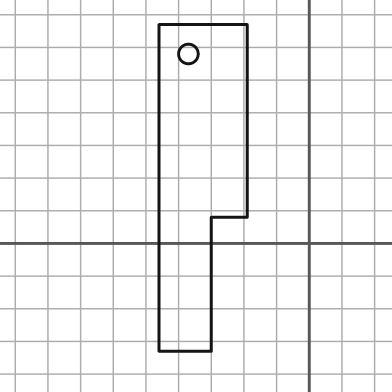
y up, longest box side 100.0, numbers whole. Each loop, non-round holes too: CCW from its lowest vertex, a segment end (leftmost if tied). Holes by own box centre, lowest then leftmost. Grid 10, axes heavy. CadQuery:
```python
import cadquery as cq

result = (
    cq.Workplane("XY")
    .moveTo(-46.0, -33.0)
    .lineTo(-30.0, -33.0)
    .lineTo(-30.0, 8.0)
    .lineTo(-19.0, 8.0)
    .lineTo(-19.0, 67.0)
    .lineTo(-46.0, 67.0)
    .close()
    .moveTo(-37.0, 58.0)
    .circle(3.0)
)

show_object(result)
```